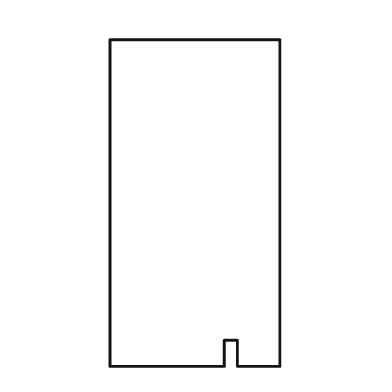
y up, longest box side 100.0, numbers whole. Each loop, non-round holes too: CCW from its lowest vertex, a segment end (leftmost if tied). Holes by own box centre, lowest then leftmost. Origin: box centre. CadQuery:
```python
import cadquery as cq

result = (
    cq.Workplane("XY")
    .moveTo(-26.0, -50.0)
    .lineTo(9.0, -50.0)
    .lineTo(9.0, -42.0)
    .lineTo(13.0, -42.0)
    .lineTo(13.0, -50.0)
    .lineTo(26.0, -50.0)
    .lineTo(26.0, 50.0)
    .lineTo(-26.0, 50.0)
    .close()
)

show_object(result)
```